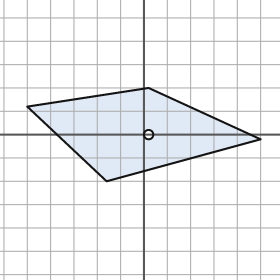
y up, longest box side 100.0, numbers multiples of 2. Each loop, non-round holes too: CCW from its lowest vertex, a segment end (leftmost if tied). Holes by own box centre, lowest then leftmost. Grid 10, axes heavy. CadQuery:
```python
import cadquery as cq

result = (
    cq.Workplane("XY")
    .moveTo(-16.0, -20.0)
    .lineTo(50.0, -2.0)
    .lineTo(2.0, 20.0)
    .lineTo(-50.0, 12.0)
    .close()
    .moveTo(2.0, 0.0)
    .circle(2.0)
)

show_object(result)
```